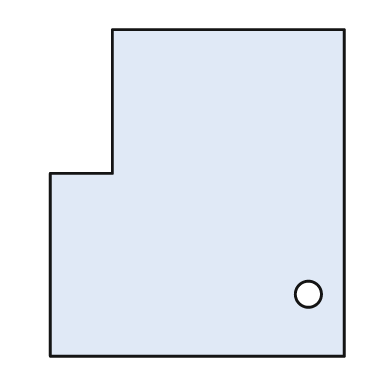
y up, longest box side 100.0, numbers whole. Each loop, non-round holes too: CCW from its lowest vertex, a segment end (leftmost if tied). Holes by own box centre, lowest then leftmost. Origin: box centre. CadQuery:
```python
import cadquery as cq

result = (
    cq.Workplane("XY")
    .moveTo(-45.0, -50.0)
    .lineTo(45.0, -50.0)
    .lineTo(45.0, 50.0)
    .lineTo(-26.0, 50.0)
    .lineTo(-26.0, 6.0)
    .lineTo(-45.0, 6.0)
    .close()
    .moveTo(34.0, -31.0)
    .circle(4.0)
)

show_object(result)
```